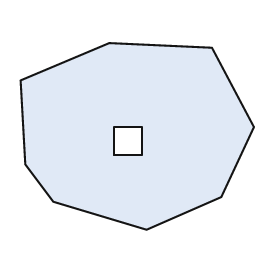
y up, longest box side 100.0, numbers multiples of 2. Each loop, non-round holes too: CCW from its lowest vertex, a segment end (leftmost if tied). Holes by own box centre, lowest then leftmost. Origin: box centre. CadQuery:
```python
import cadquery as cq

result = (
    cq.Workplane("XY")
    .moveTo(4.0, -40.0)
    .lineTo(36.0, -26.0)
    .lineTo(50.0, 4.0)
    .lineTo(32.0, 38.0)
    .lineTo(-12.0, 40.0)
    .lineTo(-50.0, 24.0)
    .lineTo(-48.0, -12.0)
    .lineTo(-36.0, -28.0)
    .close()
    .moveTo(-10.0, -8.0)
    .lineTo(2.0, -8.0)
    .lineTo(2.0, 4.0)
    .lineTo(-10.0, 4.0)
    .close()
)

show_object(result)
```